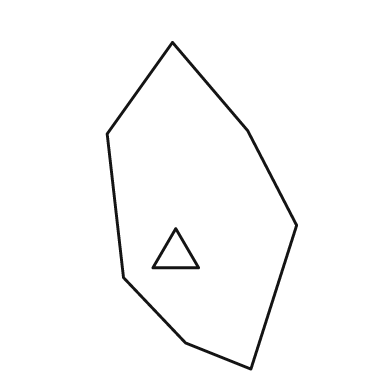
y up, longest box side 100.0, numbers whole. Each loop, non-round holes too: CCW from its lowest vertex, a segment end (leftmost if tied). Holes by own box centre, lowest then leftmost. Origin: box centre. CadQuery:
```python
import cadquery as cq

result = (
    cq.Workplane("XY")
    .moveTo(15.0, -50.0)
    .lineTo(29.0, -6.0)
    .lineTo(14.0, 23.0)
    .lineTo(-9.0, 50.0)
    .lineTo(-29.0, 22.0)
    .lineTo(-24.0, -22.0)
    .lineTo(-5.0, -42.0)
    .close()
    .moveTo(-15.0, -19.0)
    .lineTo(-1.0, -19.0)
    .lineTo(-8.0, -7.0)
    .close()
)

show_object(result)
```